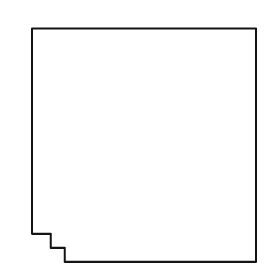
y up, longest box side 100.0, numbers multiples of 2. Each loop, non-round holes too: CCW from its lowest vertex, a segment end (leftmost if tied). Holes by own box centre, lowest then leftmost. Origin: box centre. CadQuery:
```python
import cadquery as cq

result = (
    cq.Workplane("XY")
    .moveTo(-34.0, -50.0)
    .lineTo(48.0, -50.0)
    .lineTo(48.0, 50.0)
    .lineTo(-48.0, 50.0)
    .lineTo(-48.0, -38.0)
    .lineTo(-40.0, -38.0)
    .lineTo(-40.0, -44.0)
    .lineTo(-34.0, -44.0)
    .close()
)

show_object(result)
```